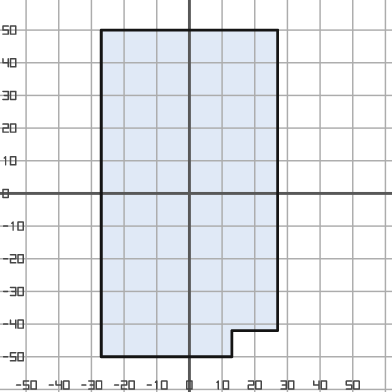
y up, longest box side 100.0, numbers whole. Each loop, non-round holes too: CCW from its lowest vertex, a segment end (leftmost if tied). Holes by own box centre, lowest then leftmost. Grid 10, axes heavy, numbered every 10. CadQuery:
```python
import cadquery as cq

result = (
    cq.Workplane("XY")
    .moveTo(-27.0, -50.0)
    .lineTo(13.0, -50.0)
    .lineTo(13.0, -42.0)
    .lineTo(27.0, -42.0)
    .lineTo(27.0, 50.0)
    .lineTo(-27.0, 50.0)
    .close()
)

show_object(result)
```